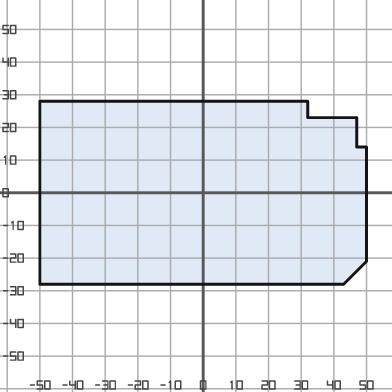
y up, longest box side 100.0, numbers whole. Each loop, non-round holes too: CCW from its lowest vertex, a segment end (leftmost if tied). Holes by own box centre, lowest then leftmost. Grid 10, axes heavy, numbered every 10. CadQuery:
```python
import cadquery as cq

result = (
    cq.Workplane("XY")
    .moveTo(-50.0, -28.0)
    .lineTo(43.0, -28.0)
    .lineTo(50.0, -21.0)
    .lineTo(50.0, 14.0)
    .lineTo(47.0, 14.0)
    .lineTo(47.0, 23.0)
    .lineTo(32.0, 23.0)
    .lineTo(32.0, 28.0)
    .lineTo(-50.0, 28.0)
    .close()
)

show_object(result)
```